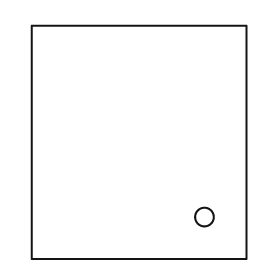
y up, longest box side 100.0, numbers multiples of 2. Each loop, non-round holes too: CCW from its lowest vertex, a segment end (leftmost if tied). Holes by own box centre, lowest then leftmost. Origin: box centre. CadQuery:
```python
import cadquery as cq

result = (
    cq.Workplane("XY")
    .moveTo(-46.0, -50.0)
    .lineTo(46.0, -50.0)
    .lineTo(46.0, 50.0)
    .lineTo(-46.0, 50.0)
    .close()
    .moveTo(28.0, -32.0)
    .circle(4.0)
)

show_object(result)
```